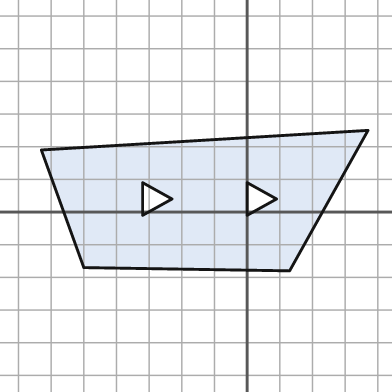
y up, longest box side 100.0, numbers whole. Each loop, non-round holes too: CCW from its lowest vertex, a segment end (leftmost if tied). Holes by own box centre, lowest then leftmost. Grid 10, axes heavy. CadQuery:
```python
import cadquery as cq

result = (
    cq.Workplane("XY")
    .moveTo(13.0, -18.0)
    .lineTo(37.0, 25.0)
    .lineTo(-63.0, 19.0)
    .lineTo(-50.0, -17.0)
    .close()
    .moveTo(-32.0, -1.0)
    .lineTo(-23.0, 4.0)
    .lineTo(-32.0, 9.0)
    .close()
    .moveTo(0.0, -1.0)
    .lineTo(9.0, 4.0)
    .lineTo(0.0, 9.0)
    .close()
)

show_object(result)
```